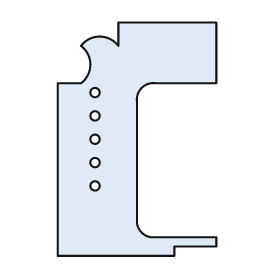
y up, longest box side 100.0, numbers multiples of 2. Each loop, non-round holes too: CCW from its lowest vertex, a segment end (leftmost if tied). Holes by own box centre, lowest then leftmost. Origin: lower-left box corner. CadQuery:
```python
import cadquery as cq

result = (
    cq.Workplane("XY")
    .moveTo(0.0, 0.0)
    .lineTo(50.0, 0.0)
    .lineTo(50.0, 4.0)
    .lineTo(68.0, 4.0)
    .lineTo(68.0, 8.0)
    .lineTo(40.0, 8.0)
    .threePointArc((36.0, 10.0), (34.0, 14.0))
    .lineTo(34.0, 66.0)
    .threePointArc((36.0, 72.0), (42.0, 74.0))
    .lineTo(68.0, 74.0)
    .lineTo(68.0, 100.0)
    .lineTo(26.0, 100.0)
    .lineTo(26.0, 90.0)
    .threePointArc((18.0, 94.0), (10.0, 90.0))
    .threePointArc((14.0, 82.0), (10.0, 74.0))
    .lineTo(0.0, 74.0)
    .close()
    .moveTo(16.0, 30.0)
    .circle(2.0)
    .moveTo(16.0, 40.0)
    .circle(2.0)
    .moveTo(16.0, 50.0)
    .circle(2.0)
    .moveTo(16.0, 60.0)
    .circle(2.0)
    .moveTo(16.0, 70.0)
    .circle(2.0)
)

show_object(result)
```